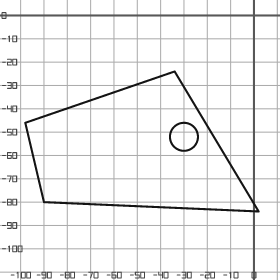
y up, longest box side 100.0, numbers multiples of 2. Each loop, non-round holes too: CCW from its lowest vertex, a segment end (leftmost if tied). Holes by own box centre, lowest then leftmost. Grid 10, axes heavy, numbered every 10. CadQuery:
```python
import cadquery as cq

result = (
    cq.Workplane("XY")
    .moveTo(2.0, -84.0)
    .lineTo(-34.0, -24.0)
    .lineTo(-98.0, -46.0)
    .lineTo(-90.0, -80.0)
    .close()
    .moveTo(-30.0, -52.0)
    .circle(6.0)
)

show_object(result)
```